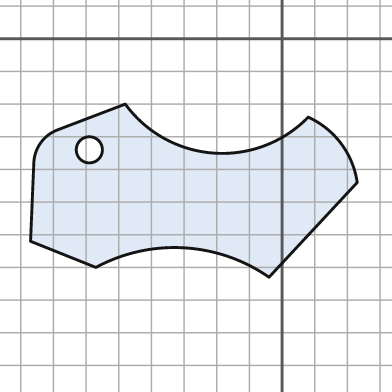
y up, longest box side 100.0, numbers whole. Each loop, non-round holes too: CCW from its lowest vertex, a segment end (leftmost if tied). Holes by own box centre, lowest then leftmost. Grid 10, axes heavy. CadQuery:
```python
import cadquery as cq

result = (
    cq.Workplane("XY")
    .moveTo(-4.0, -73.0)
    .lineTo(23.0, -44.0)
    .threePointArc((18.0, -32.0), (8.0, -24.0))
    .threePointArc((-21.0, -35.0), (-48.0, -20.0))
    .lineTo(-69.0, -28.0)
    .threePointArc((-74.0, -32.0), (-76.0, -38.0))
    .lineTo(-77.0, -62.0)
    .lineTo(-57.0, -70.0)
    .threePointArc((-30.0, -64.0), (-4.0, -73.0))
    .close()
    .moveTo(-59.0, -34.0)
    .circle(4.0)
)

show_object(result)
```